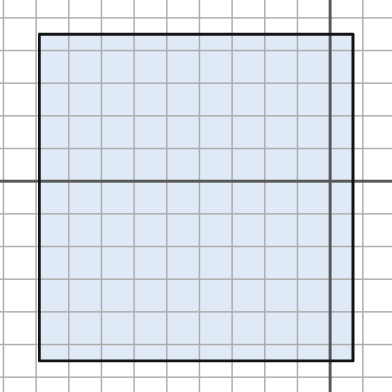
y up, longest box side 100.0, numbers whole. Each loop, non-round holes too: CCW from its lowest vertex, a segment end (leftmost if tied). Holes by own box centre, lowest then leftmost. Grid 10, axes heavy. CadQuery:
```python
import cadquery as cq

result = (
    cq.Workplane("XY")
    .moveTo(-89.0, -55.0)
    .lineTo(7.0, -55.0)
    .lineTo(7.0, 45.0)
    .lineTo(-89.0, 45.0)
    .close()
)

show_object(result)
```